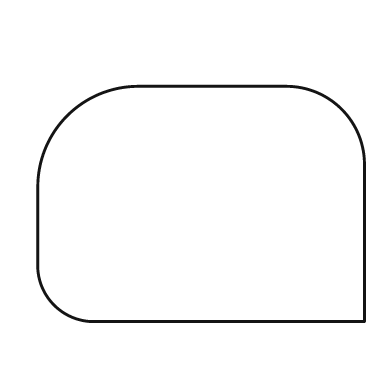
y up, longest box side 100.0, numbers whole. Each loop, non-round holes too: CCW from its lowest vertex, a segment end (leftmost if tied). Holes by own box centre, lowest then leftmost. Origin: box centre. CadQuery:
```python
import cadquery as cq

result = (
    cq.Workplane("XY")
    .moveTo(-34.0, -36.0)
    .lineTo(50.0, -36.0)
    .lineTo(50.0, 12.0)
    .threePointArc((43.0, 29.0), (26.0, 36.0))
    .lineTo(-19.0, 36.0)
    .threePointArc((-41.0, 27.0), (-50.0, 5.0))
    .lineTo(-50.0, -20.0)
    .threePointArc((-45.0, -31.0), (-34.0, -36.0))
    .close()
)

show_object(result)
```